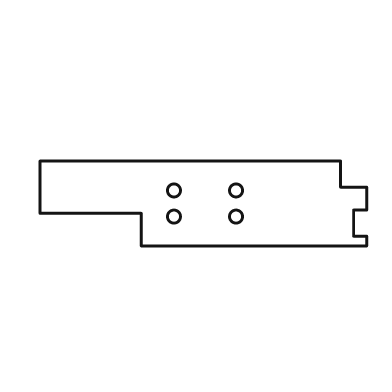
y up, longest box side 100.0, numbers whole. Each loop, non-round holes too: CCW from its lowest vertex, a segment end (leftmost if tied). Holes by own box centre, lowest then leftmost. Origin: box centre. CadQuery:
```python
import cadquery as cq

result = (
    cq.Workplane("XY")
    .moveTo(-19.0, -13.0)
    .lineTo(50.0, -13.0)
    .lineTo(50.0, -10.0)
    .lineTo(46.0, -10.0)
    .lineTo(46.0, -2.0)
    .lineTo(50.0, -2.0)
    .lineTo(50.0, 5.0)
    .lineTo(42.0, 5.0)
    .lineTo(42.0, 13.0)
    .lineTo(-50.0, 13.0)
    .lineTo(-50.0, -3.0)
    .lineTo(-19.0, -3.0)
    .close()
    .moveTo(-9.0, -4.0)
    .circle(2.0)
    .moveTo(10.0, -4.0)
    .circle(2.0)
    .moveTo(-9.0, 4.0)
    .circle(2.0)
    .moveTo(10.0, 4.0)
    .circle(2.0)
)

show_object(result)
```